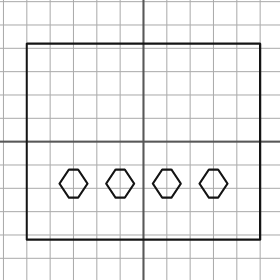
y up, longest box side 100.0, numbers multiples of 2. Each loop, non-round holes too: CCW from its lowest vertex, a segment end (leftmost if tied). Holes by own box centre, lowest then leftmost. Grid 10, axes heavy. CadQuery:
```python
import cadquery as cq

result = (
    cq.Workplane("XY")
    .moveTo(-50.0, -42.0)
    .lineTo(50.0, -42.0)
    .lineTo(50.0, 42.0)
    .lineTo(-50.0, 42.0)
    .close()
    .moveTo(-32.0, -24.0)
    .lineTo(-28.0, -24.0)
    .lineTo(-24.0, -18.0)
    .lineTo(-28.0, -12.0)
    .lineTo(-32.0, -12.0)
    .lineTo(-36.0, -18.0)
    .close()
    .moveTo(-12.0, -24.0)
    .lineTo(-8.0, -24.0)
    .lineTo(-4.0, -18.0)
    .lineTo(-8.0, -12.0)
    .lineTo(-12.0, -12.0)
    .lineTo(-16.0, -18.0)
    .close()
    .moveTo(8.0, -24.0)
    .lineTo(12.0, -24.0)
    .lineTo(16.0, -18.0)
    .lineTo(12.0, -12.0)
    .lineTo(8.0, -12.0)
    .lineTo(4.0, -18.0)
    .close()
    .moveTo(28.0, -24.0)
    .lineTo(32.0, -24.0)
    .lineTo(36.0, -18.0)
    .lineTo(32.0, -12.0)
    .lineTo(28.0, -12.0)
    .lineTo(24.0, -18.0)
    .close()
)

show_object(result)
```